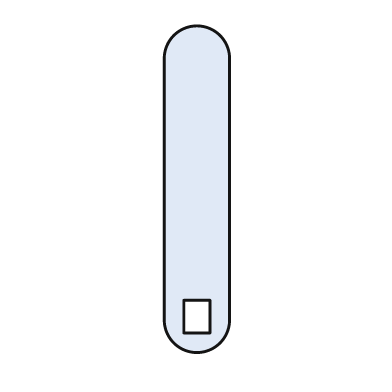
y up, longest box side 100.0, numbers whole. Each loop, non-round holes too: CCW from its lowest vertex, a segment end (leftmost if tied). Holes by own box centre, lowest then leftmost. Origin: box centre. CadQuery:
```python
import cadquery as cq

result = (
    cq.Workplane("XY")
    .moveTo(-10.0, -40.0)
    .threePointArc((0.0, -50.0), (10.0, -40.0))
    .lineTo(10.0, 40.0)
    .threePointArc((0.0, 50.0), (-10.0, 40.0))
    .close()
    .moveTo(-4.0, -44.0)
    .lineTo(4.0, -44.0)
    .lineTo(4.0, -34.0)
    .lineTo(-4.0, -34.0)
    .close()
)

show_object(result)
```